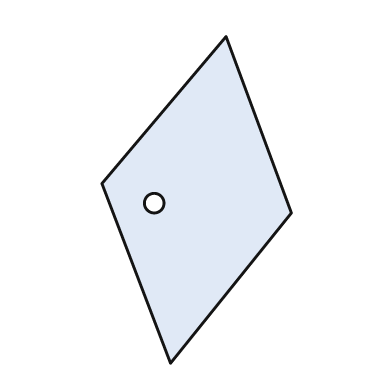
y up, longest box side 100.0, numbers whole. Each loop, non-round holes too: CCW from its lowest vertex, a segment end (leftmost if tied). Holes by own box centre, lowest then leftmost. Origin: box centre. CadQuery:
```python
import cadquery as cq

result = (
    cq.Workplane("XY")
    .moveTo(-8.0, -50.0)
    .lineTo(29.0, -4.0)
    .lineTo(9.0, 50.0)
    .lineTo(-29.0, 5.0)
    .close()
    .moveTo(-13.0, -1.0)
    .circle(3.0)
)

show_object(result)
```